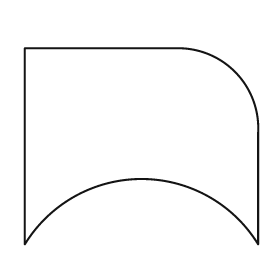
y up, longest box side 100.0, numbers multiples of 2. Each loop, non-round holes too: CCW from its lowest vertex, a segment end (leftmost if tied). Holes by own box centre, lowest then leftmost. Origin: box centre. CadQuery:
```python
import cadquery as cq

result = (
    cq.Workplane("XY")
    .moveTo(-50.0, -42.0)
    .threePointArc((0.0, -14.0), (50.0, -42.0))
    .lineTo(50.0, 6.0)
    .threePointArc((40.0, 32.0), (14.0, 42.0))
    .lineTo(-50.0, 42.0)
    .close()
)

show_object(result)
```